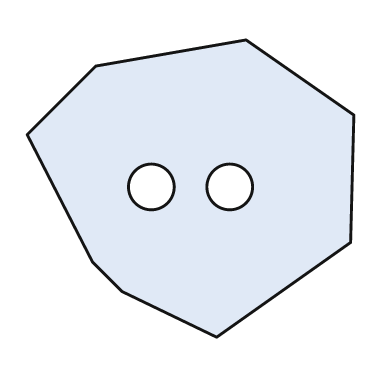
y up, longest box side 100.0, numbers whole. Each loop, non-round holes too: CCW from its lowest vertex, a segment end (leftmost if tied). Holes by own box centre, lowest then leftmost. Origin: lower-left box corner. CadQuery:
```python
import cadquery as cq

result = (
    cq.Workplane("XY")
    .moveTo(58.0, 0.0)
    .lineTo(99.0, 29.0)
    .lineTo(100.0, 68.0)
    .lineTo(67.0, 91.0)
    .lineTo(21.0, 83.0)
    .lineTo(0.0, 62.0)
    .lineTo(20.0, 23.0)
    .lineTo(29.0, 14.0)
    .close()
    .moveTo(38.0, 46.0)
    .circle(7.0)
    .moveTo(62.0, 46.0)
    .circle(7.0)
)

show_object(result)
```